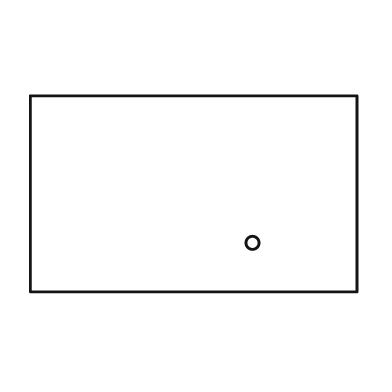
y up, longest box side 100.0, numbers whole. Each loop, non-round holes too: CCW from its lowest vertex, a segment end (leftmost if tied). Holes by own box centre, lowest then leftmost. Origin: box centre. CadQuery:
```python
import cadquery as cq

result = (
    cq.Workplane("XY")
    .moveTo(-50.0, -30.0)
    .lineTo(50.0, -30.0)
    .lineTo(50.0, 30.0)
    .lineTo(-50.0, 30.0)
    .close()
    .moveTo(18.0, -15.0)
    .circle(2.0)
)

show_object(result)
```